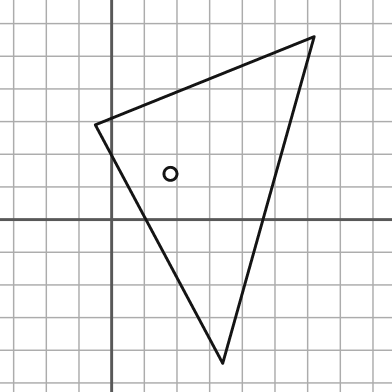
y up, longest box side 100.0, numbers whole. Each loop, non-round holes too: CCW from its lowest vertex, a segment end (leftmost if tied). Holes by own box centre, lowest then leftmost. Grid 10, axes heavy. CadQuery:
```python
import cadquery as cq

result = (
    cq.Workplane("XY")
    .moveTo(34.0, -44.0)
    .lineTo(62.0, 56.0)
    .lineTo(-5.0, 29.0)
    .close()
    .moveTo(18.0, 14.0)
    .circle(2.0)
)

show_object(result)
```